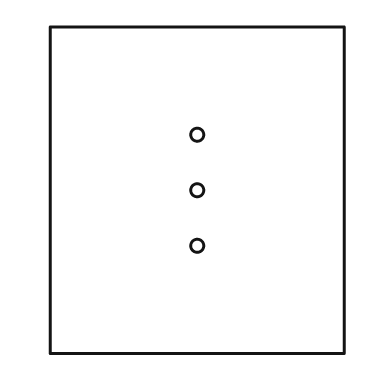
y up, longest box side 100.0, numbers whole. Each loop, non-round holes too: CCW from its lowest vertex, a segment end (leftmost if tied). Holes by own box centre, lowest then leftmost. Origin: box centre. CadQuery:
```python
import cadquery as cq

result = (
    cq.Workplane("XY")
    .moveTo(-45.0, -50.0)
    .lineTo(45.0, -50.0)
    .lineTo(45.0, 50.0)
    .lineTo(-45.0, 50.0)
    .close()
    .moveTo(0.0, -17.0)
    .circle(2.0)
    .moveTo(0.0, 0.0)
    .circle(2.0)
    .moveTo(0.0, 17.0)
    .circle(2.0)
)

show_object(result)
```